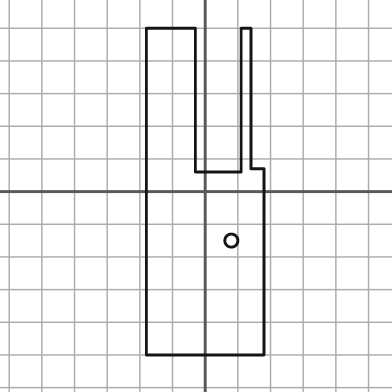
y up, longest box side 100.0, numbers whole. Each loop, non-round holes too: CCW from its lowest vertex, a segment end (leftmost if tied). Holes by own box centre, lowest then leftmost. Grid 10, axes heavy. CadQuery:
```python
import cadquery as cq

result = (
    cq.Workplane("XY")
    .moveTo(-18.0, -50.0)
    .lineTo(18.0, -50.0)
    .lineTo(18.0, 7.0)
    .lineTo(14.0, 7.0)
    .lineTo(14.0, 50.0)
    .lineTo(11.0, 50.0)
    .lineTo(11.0, 6.0)
    .lineTo(-3.0, 6.0)
    .lineTo(-3.0, 50.0)
    .lineTo(-18.0, 50.0)
    .close()
    .moveTo(8.0, -15.0)
    .circle(2.0)
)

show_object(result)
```